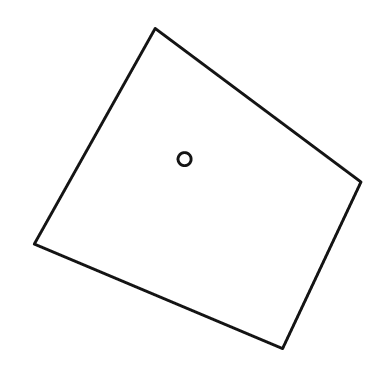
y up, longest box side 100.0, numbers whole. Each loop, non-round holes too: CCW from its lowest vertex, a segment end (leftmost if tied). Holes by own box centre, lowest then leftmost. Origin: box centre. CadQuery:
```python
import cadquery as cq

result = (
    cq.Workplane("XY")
    .moveTo(26.0, -49.0)
    .lineTo(50.0, 2.0)
    .lineTo(-13.0, 49.0)
    .lineTo(-50.0, -17.0)
    .close()
    .moveTo(-4.0, 9.0)
    .circle(2.0)
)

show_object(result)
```